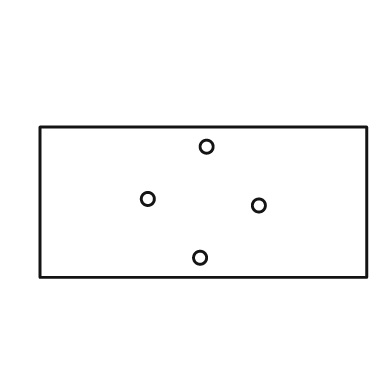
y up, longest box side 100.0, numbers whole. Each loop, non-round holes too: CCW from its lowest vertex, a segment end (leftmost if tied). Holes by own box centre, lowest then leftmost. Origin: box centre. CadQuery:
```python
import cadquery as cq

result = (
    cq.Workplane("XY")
    .moveTo(-50.0, -23.0)
    .lineTo(50.0, -23.0)
    .lineTo(50.0, 23.0)
    .lineTo(-50.0, 23.0)
    .close()
    .moveTo(-1.0, -17.0)
    .circle(2.0)
    .moveTo(17.0, -1.0)
    .circle(2.0)
    .moveTo(-17.0, 1.0)
    .circle(2.0)
    .moveTo(1.0, 17.0)
    .circle(2.0)
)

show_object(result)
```